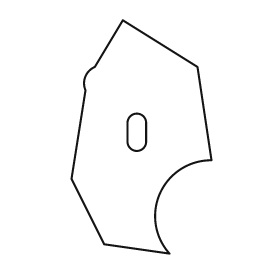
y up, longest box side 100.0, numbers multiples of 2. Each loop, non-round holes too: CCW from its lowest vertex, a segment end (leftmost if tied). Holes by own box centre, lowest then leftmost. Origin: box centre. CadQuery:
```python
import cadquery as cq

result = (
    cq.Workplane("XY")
    .moveTo(12.0, -50.0)
    .threePointArc((8.0, -24.0), (30.0, -10.0))
    .lineTo(24.0, 30.0)
    .lineTo(-8.0, 50.0)
    .lineTo(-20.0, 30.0)
    .threePointArc((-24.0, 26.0), (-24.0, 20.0))
    .lineTo(-30.0, -18.0)
    .lineTo(-16.0, -46.0)
    .close()
    .moveTo(-6.0, -2.0)
    .threePointArc((-2.0, -6.0), (2.0, -2.0))
    .lineTo(2.0, 6.0)
    .threePointArc((-2.0, 10.0), (-6.0, 6.0))
    .close()
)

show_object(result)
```